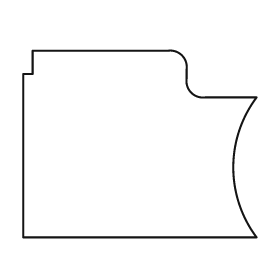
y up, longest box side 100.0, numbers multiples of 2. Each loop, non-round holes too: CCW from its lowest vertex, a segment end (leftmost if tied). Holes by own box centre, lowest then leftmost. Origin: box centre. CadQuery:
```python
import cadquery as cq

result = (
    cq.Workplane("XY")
    .moveTo(-50.0, -40.0)
    .lineTo(50.0, -40.0)
    .threePointArc((40.0, -10.0), (50.0, 20.0))
    .lineTo(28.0, 20.0)
    .threePointArc((22.0, 22.0), (20.0, 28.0))
    .lineTo(20.0, 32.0)
    .threePointArc((18.0, 38.0), (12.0, 40.0))
    .lineTo(-46.0, 40.0)
    .lineTo(-46.0, 30.0)
    .lineTo(-50.0, 30.0)
    .close()
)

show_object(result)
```